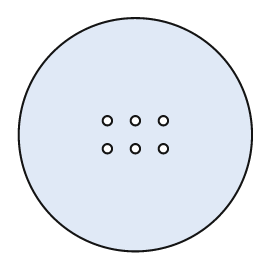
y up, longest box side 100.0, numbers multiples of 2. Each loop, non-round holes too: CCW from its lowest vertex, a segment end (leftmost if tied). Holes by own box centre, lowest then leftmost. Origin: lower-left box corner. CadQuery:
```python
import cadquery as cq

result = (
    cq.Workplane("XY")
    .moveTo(50.0, 50.0)
    .circle(50.0)
    .moveTo(38.0, 44.0)
    .circle(2.0)
    .moveTo(50.0, 44.0)
    .circle(2.0)
    .moveTo(62.0, 44.0)
    .circle(2.0)
    .moveTo(38.0, 56.0)
    .circle(2.0)
    .moveTo(50.0, 56.0)
    .circle(2.0)
    .moveTo(62.0, 56.0)
    .circle(2.0)
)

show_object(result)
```